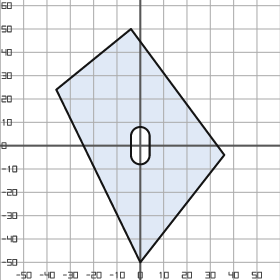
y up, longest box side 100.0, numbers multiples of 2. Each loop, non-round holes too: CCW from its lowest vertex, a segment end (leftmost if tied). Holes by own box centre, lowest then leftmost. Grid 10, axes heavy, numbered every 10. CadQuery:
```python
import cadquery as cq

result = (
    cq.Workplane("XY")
    .moveTo(0.0, -50.0)
    .lineTo(36.0, -4.0)
    .lineTo(-4.0, 50.0)
    .lineTo(-36.0, 24.0)
    .close()
    .moveTo(-4.0, -4.0)
    .threePointArc((0.0, -8.0), (4.0, -4.0))
    .lineTo(4.0, 4.0)
    .threePointArc((0.0, 8.0), (-4.0, 4.0))
    .close()
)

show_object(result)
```